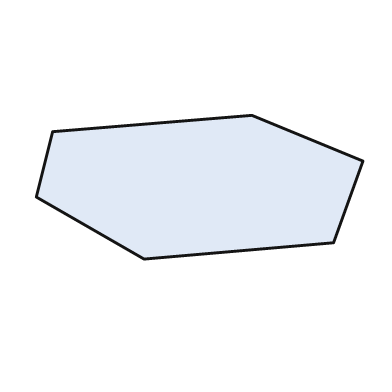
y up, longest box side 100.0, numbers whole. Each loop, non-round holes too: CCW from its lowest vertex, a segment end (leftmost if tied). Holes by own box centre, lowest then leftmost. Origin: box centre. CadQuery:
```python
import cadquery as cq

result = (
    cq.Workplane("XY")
    .moveTo(-17.0, -22.0)
    .lineTo(41.0, -17.0)
    .lineTo(50.0, 8.0)
    .lineTo(16.0, 22.0)
    .lineTo(-45.0, 17.0)
    .lineTo(-50.0, -3.0)
    .close()
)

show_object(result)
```